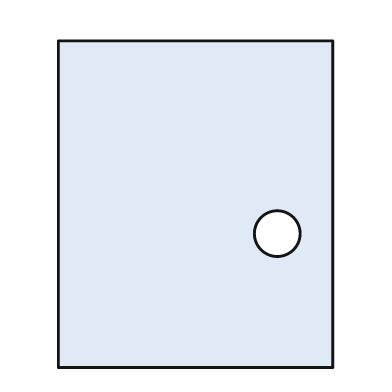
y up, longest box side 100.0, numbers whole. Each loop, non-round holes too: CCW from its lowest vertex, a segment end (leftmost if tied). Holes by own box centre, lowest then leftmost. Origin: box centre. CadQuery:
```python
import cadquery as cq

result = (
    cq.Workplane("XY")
    .moveTo(-42.0, -50.0)
    .lineTo(42.0, -50.0)
    .lineTo(42.0, 50.0)
    .lineTo(-42.0, 50.0)
    .close()
    .moveTo(25.0, -9.0)
    .circle(7.0)
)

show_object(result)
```